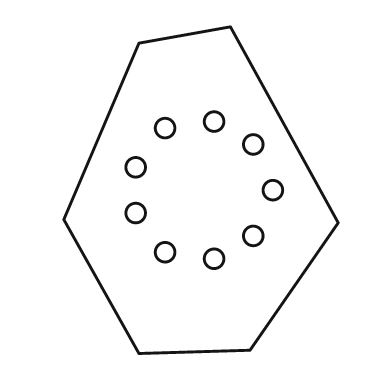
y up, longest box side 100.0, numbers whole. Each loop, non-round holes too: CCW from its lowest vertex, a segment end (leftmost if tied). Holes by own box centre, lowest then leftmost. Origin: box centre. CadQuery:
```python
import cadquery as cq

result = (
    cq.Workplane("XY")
    .moveTo(-19.0, -50.0)
    .lineTo(15.0, -49.0)
    .lineTo(42.0, -10.0)
    .lineTo(9.0, 50.0)
    .lineTo(-19.0, 45.0)
    .lineTo(-42.0, -9.0)
    .close()
    .moveTo(4.0, -21.0)
    .circle(3.0)
    .moveTo(-11.0, -19.0)
    .circle(3.0)
    .moveTo(16.0, -14.0)
    .circle(3.0)
    .moveTo(-20.0, -7.0)
    .circle(3.0)
    .moveTo(22.0, 0.0)
    .circle(3.0)
    .moveTo(-20.0, 7.0)
    .circle(3.0)
    .moveTo(16.0, 14.0)
    .circle(3.0)
    .moveTo(-11.0, 19.0)
    .circle(3.0)
    .moveTo(4.0, 21.0)
    .circle(3.0)
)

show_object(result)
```